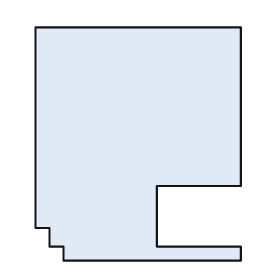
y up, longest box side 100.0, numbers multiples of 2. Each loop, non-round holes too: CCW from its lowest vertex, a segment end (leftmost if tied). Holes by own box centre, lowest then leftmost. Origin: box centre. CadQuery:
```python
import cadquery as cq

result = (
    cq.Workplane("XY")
    .moveTo(-32.0, -50.0)
    .lineTo(44.0, -50.0)
    .lineTo(44.0, -44.0)
    .lineTo(8.0, -44.0)
    .lineTo(8.0, -18.0)
    .lineTo(44.0, -18.0)
    .lineTo(44.0, 50.0)
    .lineTo(-44.0, 50.0)
    .lineTo(-44.0, -36.0)
    .lineTo(-38.0, -36.0)
    .lineTo(-38.0, -44.0)
    .lineTo(-32.0, -44.0)
    .close()
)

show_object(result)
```